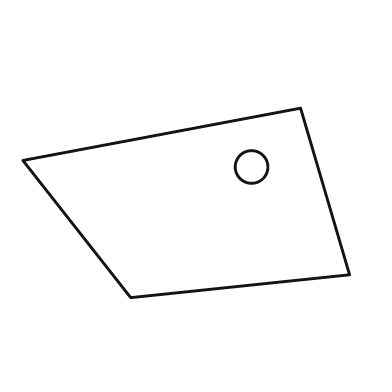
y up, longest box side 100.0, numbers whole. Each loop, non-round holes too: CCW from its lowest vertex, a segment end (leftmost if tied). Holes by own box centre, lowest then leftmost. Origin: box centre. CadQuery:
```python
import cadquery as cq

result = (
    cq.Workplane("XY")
    .moveTo(-17.0, -29.0)
    .lineTo(50.0, -22.0)
    .lineTo(35.0, 29.0)
    .lineTo(-50.0, 13.0)
    .close()
    .moveTo(20.0, 11.0)
    .circle(5.0)
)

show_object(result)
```